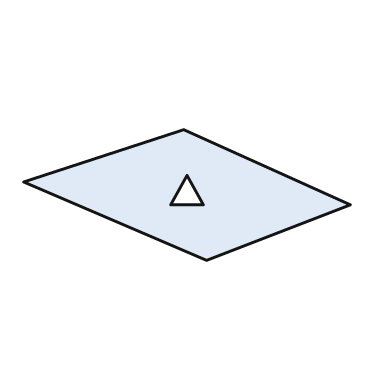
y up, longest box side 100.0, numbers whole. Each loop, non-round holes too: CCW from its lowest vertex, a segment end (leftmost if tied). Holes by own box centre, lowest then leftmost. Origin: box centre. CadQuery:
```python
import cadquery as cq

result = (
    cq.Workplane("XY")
    .moveTo(6.0, -20.0)
    .lineTo(50.0, -3.0)
    .lineTo(-1.0, 20.0)
    .lineTo(-50.0, 4.0)
    .close()
    .moveTo(-5.0, -3.0)
    .lineTo(5.0, -3.0)
    .lineTo(0.0, 6.0)
    .close()
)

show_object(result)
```